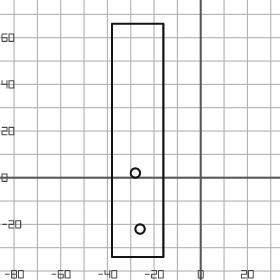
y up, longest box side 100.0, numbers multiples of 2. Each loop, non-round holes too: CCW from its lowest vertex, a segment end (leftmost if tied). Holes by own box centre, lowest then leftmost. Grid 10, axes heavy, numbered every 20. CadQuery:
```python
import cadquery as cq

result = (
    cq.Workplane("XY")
    .moveTo(-38.0, -34.0)
    .lineTo(-16.0, -34.0)
    .lineTo(-16.0, 66.0)
    .lineTo(-38.0, 66.0)
    .close()
    .moveTo(-26.0, -22.0)
    .circle(2.0)
    .moveTo(-28.0, 2.0)
    .circle(2.0)
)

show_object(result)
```